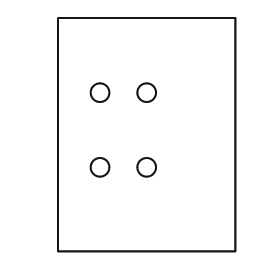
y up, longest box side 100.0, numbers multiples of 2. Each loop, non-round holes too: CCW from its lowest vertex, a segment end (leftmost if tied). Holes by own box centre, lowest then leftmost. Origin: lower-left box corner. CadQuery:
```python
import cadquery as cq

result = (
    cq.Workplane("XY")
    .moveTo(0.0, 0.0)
    .lineTo(76.0, 0.0)
    .lineTo(76.0, 100.0)
    .lineTo(0.0, 100.0)
    .close()
    .moveTo(18.0, 36.0)
    .circle(4.0)
    .moveTo(38.0, 36.0)
    .circle(4.0)
    .moveTo(18.0, 68.0)
    .circle(4.0)
    .moveTo(38.0, 68.0)
    .circle(4.0)
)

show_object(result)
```